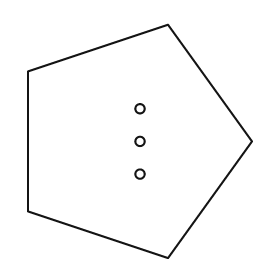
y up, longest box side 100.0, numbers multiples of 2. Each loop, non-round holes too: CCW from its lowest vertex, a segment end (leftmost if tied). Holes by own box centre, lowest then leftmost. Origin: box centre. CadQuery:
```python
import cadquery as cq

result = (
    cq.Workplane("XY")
    .moveTo(12.0, -50.0)
    .lineTo(48.0, 0.0)
    .lineTo(12.0, 50.0)
    .lineTo(-48.0, 30.0)
    .lineTo(-48.0, -30.0)
    .close()
    .moveTo(0.0, -14.0)
    .circle(2.0)
    .moveTo(0.0, 0.0)
    .circle(2.0)
    .moveTo(0.0, 14.0)
    .circle(2.0)
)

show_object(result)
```